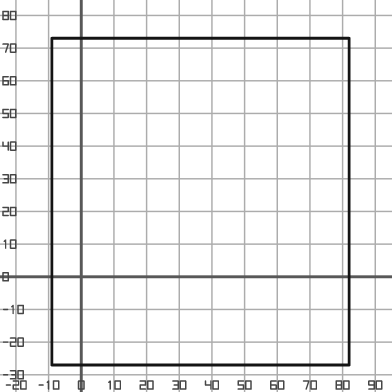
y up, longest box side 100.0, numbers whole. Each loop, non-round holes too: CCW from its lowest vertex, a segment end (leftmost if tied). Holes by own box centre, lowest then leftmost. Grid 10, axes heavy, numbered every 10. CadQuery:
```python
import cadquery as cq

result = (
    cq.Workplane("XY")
    .moveTo(-9.0, -27.0)
    .lineTo(82.0, -27.0)
    .lineTo(82.0, 73.0)
    .lineTo(-9.0, 73.0)
    .close()
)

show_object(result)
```